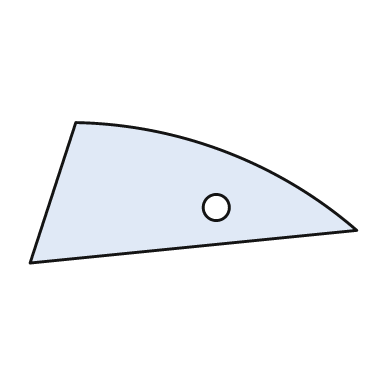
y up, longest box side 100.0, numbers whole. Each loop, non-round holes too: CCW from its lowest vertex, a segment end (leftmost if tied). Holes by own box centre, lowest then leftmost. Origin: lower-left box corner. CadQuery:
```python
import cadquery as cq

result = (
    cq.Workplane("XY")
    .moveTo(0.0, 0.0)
    .lineTo(100.0, 10.0)
    .threePointArc((60.0, 34.0), (14.0, 43.0))
    .close()
    .moveTo(57.0, 17.0)
    .circle(4.0)
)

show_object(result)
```